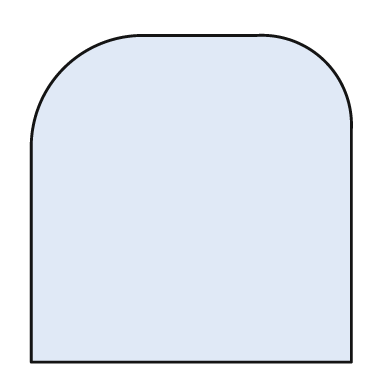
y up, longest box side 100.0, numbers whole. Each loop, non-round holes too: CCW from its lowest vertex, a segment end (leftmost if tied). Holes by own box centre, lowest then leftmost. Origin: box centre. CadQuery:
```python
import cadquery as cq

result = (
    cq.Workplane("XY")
    .moveTo(-49.0, -50.0)
    .lineTo(49.0, -50.0)
    .lineTo(49.0, 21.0)
    .threePointArc((41.0, 42.0), (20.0, 50.0))
    .lineTo(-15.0, 50.0)
    .threePointArc((-39.0, 40.0), (-49.0, 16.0))
    .close()
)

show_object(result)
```